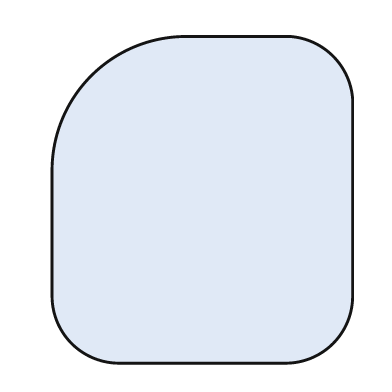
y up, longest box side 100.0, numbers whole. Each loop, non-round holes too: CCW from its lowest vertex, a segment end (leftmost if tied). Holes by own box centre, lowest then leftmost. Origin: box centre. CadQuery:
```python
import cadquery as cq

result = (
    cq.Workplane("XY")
    .moveTo(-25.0, -50.0)
    .lineTo(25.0, -50.0)
    .threePointArc((40.0, -44.0), (46.0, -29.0))
    .lineTo(46.0, 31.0)
    .threePointArc((40.0, 44.0), (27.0, 50.0))
    .lineTo(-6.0, 50.0)
    .threePointArc((-34.0, 38.0), (-46.0, 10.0))
    .lineTo(-46.0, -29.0)
    .threePointArc((-40.0, -44.0), (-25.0, -50.0))
    .close()
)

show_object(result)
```